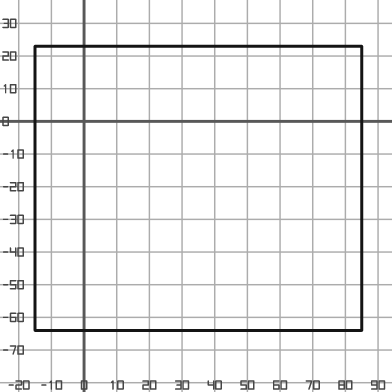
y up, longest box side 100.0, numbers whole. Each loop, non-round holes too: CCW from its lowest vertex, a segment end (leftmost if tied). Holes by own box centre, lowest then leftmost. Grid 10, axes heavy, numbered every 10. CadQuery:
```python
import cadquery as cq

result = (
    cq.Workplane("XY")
    .moveTo(-15.0, -64.0)
    .lineTo(85.0, -64.0)
    .lineTo(85.0, 23.0)
    .lineTo(-15.0, 23.0)
    .close()
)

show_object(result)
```